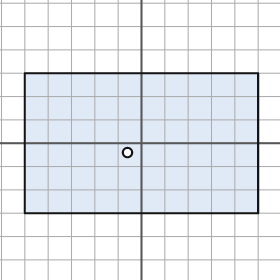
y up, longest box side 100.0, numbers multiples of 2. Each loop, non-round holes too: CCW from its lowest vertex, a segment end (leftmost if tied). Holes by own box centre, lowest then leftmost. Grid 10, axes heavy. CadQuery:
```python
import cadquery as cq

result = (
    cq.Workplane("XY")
    .moveTo(-50.0, -30.0)
    .lineTo(50.0, -30.0)
    .lineTo(50.0, 30.0)
    .lineTo(-50.0, 30.0)
    .close()
    .moveTo(-6.0, -4.0)
    .circle(2.0)
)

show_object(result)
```